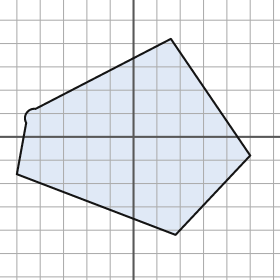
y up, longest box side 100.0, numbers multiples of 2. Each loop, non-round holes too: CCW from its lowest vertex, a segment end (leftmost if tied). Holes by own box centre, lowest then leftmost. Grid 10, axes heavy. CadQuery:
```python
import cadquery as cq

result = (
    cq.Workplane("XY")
    .moveTo(18.0, -42.0)
    .lineTo(50.0, -8.0)
    .lineTo(16.0, 42.0)
    .lineTo(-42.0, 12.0)
    .threePointArc((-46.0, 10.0), (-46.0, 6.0))
    .lineTo(-50.0, -16.0)
    .close()
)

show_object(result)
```